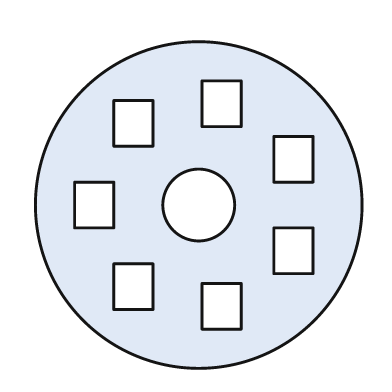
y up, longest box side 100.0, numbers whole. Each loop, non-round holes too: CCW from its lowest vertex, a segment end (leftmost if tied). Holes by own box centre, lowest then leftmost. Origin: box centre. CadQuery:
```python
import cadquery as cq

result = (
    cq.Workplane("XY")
    .moveTo(0.0, 0.0)
    .circle(50.0)
    .moveTo(1.0, -38.0)
    .lineTo(13.0, -38.0)
    .lineTo(13.0, -24.0)
    .lineTo(1.0, -24.0)
    .close()
    .moveTo(-26.0, -32.0)
    .lineTo(-14.0, -32.0)
    .lineTo(-14.0, -18.0)
    .lineTo(-26.0, -18.0)
    .close()
    .moveTo(23.0, -21.0)
    .lineTo(35.0, -21.0)
    .lineTo(35.0, -7.0)
    .lineTo(23.0, -7.0)
    .close()
    .moveTo(-38.0, -7.0)
    .lineTo(-26.0, -7.0)
    .lineTo(-26.0, 7.0)
    .lineTo(-38.0, 7.0)
    .close()
    .moveTo(0.0, 0.0)
    .circle(11.0)
    .moveTo(23.0, 7.0)
    .lineTo(35.0, 7.0)
    .lineTo(35.0, 21.0)
    .lineTo(23.0, 21.0)
    .close()
    .moveTo(-26.0, 18.0)
    .lineTo(-14.0, 18.0)
    .lineTo(-14.0, 32.0)
    .lineTo(-26.0, 32.0)
    .close()
    .moveTo(1.0, 24.0)
    .lineTo(13.0, 24.0)
    .lineTo(13.0, 38.0)
    .lineTo(1.0, 38.0)
    .close()
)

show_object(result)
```